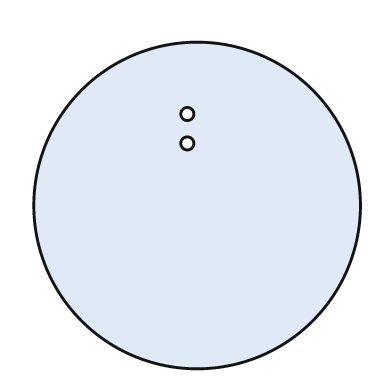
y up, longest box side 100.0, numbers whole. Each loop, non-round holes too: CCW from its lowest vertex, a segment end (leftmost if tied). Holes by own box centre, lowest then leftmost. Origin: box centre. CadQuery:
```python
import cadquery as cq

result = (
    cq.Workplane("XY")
    .moveTo(0.0, 0.0)
    .circle(50.0)
    .moveTo(-3.0, 19.0)
    .circle(2.0)
    .moveTo(-3.0, 28.0)
    .circle(2.0)
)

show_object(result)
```